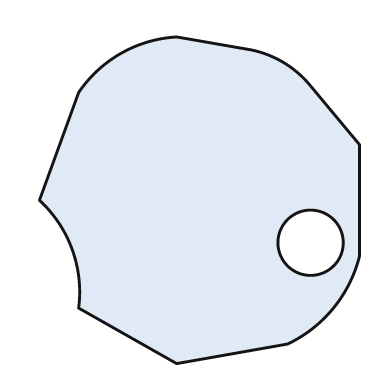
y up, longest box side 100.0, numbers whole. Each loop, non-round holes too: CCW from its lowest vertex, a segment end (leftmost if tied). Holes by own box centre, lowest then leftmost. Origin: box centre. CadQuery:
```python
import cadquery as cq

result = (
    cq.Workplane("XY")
    .moveTo(-7.0, -50.0)
    .lineTo(27.0, -44.0)
    .threePointArc((41.0, -33.0), (49.0, -17.0))
    .lineTo(49.0, 17.0)
    .lineTo(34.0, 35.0)
    .threePointArc((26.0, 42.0), (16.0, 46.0))
    .lineTo(-7.0, 50.0)
    .threePointArc((-24.0, 45.0), (-37.0, 33.0))
    .lineTo(-49.0, 0.0)
    .threePointArc((-39.0, -15.0), (-37.0, -33.0))
    .close()
    .moveTo(34.0, -13.0)
    .circle(10.0)
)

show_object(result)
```